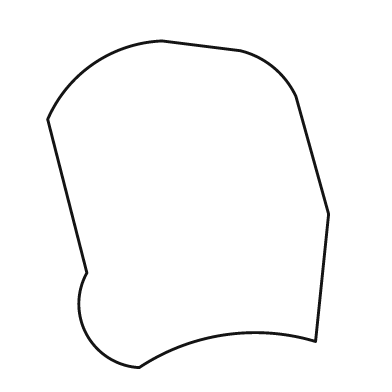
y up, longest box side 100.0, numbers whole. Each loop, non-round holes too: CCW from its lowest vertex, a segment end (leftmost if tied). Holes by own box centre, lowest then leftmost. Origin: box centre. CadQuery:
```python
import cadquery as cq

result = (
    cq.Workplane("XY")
    .moveTo(-15.0, -50.0)
    .threePointArc((11.0, -40.0), (39.0, -42.0))
    .lineTo(43.0, -3.0)
    .lineTo(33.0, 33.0)
    .threePointArc((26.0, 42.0), (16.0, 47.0))
    .lineTo(-8.0, 50.0)
    .threePointArc((-29.0, 43.0), (-43.0, 26.0))
    .lineTo(-31.0, -21.0)
    .threePointArc((-31.0, -40.0), (-15.0, -50.0))
    .close()
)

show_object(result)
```